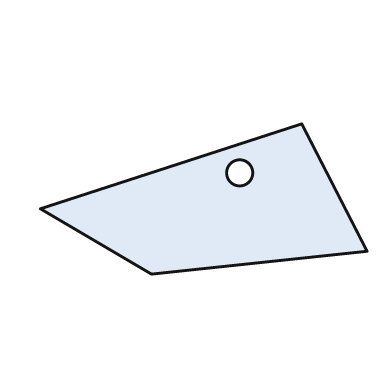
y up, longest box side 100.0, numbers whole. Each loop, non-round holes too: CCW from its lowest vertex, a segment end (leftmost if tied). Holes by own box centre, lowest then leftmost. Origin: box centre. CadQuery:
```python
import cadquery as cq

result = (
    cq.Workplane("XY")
    .moveTo(-16.0, -23.0)
    .lineTo(50.0, -16.0)
    .lineTo(30.0, 23.0)
    .lineTo(-50.0, -3.0)
    .close()
    .moveTo(11.0, 8.0)
    .circle(4.0)
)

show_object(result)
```